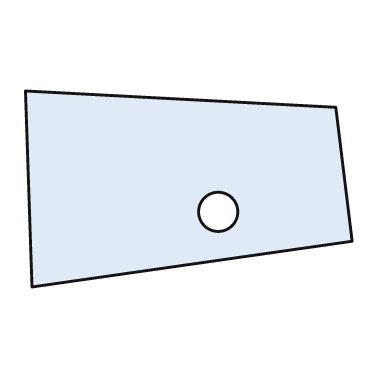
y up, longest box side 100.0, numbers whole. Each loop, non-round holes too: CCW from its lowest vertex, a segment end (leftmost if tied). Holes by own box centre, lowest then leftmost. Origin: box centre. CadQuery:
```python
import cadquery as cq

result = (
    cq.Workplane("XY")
    .moveTo(-48.0, -30.0)
    .lineTo(50.0, -16.0)
    .lineTo(45.0, 25.0)
    .lineTo(-50.0, 30.0)
    .close()
    .moveTo(9.0, -7.0)
    .circle(6.0)
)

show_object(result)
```